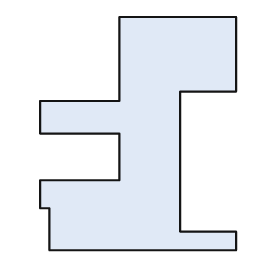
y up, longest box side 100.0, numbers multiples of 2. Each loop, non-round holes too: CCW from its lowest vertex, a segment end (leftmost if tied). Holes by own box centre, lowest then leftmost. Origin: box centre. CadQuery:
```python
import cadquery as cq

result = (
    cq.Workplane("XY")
    .moveTo(-38.0, -50.0)
    .lineTo(42.0, -50.0)
    .lineTo(42.0, -42.0)
    .lineTo(18.0, -42.0)
    .lineTo(18.0, 18.0)
    .lineTo(42.0, 18.0)
    .lineTo(42.0, 50.0)
    .lineTo(-8.0, 50.0)
    .lineTo(-8.0, 14.0)
    .lineTo(-42.0, 14.0)
    .lineTo(-42.0, 0.0)
    .lineTo(-8.0, 0.0)
    .lineTo(-8.0, -20.0)
    .lineTo(-42.0, -20.0)
    .lineTo(-42.0, -32.0)
    .lineTo(-38.0, -32.0)
    .close()
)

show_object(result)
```